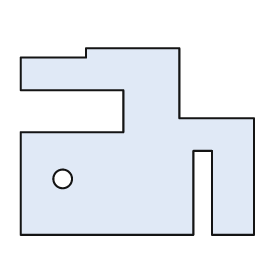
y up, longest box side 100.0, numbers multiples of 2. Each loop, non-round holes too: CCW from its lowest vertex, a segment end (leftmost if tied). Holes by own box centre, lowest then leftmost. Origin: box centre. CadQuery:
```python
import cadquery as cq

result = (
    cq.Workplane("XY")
    .moveTo(-50.0, -40.0)
    .lineTo(24.0, -40.0)
    .lineTo(24.0, -4.0)
    .lineTo(32.0, -4.0)
    .lineTo(32.0, -40.0)
    .lineTo(50.0, -40.0)
    .lineTo(50.0, 10.0)
    .lineTo(18.0, 10.0)
    .lineTo(18.0, 40.0)
    .lineTo(-22.0, 40.0)
    .lineTo(-22.0, 36.0)
    .lineTo(-50.0, 36.0)
    .lineTo(-50.0, 22.0)
    .lineTo(-6.0, 22.0)
    .lineTo(-6.0, 4.0)
    .lineTo(-50.0, 4.0)
    .close()
    .moveTo(-32.0, -16.0)
    .circle(4.0)
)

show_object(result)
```